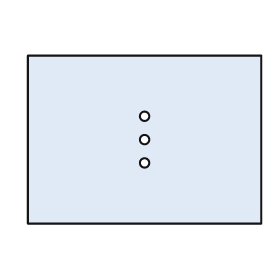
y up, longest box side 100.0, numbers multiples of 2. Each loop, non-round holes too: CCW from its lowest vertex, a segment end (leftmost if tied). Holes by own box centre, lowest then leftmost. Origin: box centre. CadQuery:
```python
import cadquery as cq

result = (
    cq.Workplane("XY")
    .moveTo(-50.0, -36.0)
    .lineTo(50.0, -36.0)
    .lineTo(50.0, 36.0)
    .lineTo(-50.0, 36.0)
    .close()
    .moveTo(0.0, -10.0)
    .circle(2.0)
    .moveTo(0.0, 0.0)
    .circle(2.0)
    .moveTo(0.0, 10.0)
    .circle(2.0)
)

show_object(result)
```